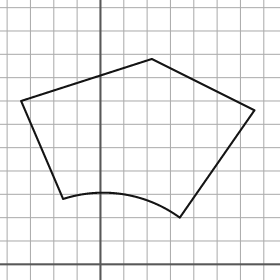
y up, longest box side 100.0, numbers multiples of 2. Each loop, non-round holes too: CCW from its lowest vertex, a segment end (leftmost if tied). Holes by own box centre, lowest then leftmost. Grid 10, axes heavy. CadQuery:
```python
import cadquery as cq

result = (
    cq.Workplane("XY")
    .moveTo(34.0, 20.0)
    .lineTo(66.0, 66.0)
    .lineTo(22.0, 88.0)
    .lineTo(-34.0, 70.0)
    .lineTo(-16.0, 28.0)
    .threePointArc((10.0, 30.0), (34.0, 20.0))
    .close()
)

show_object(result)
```